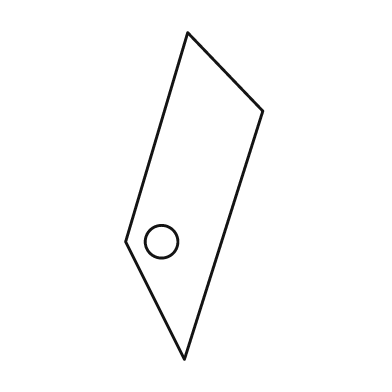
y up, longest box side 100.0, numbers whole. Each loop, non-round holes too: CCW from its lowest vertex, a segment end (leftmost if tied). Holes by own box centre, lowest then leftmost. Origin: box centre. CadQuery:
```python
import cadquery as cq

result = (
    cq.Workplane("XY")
    .moveTo(-3.0, -50.0)
    .lineTo(21.0, 26.0)
    .lineTo(-2.0, 50.0)
    .lineTo(-21.0, -14.0)
    .close()
    .moveTo(-10.0, -14.0)
    .circle(5.0)
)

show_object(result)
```